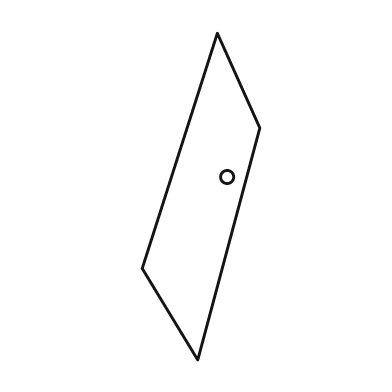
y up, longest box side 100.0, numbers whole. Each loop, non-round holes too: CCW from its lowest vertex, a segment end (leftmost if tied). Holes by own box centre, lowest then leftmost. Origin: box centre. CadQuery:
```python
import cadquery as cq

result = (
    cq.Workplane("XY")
    .moveTo(-1.0, -50.0)
    .lineTo(18.0, 21.0)
    .lineTo(5.0, 50.0)
    .lineTo(-18.0, -22.0)
    .close()
    .moveTo(8.0, 6.0)
    .circle(2.0)
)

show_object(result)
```